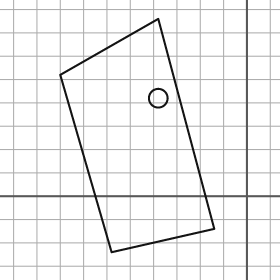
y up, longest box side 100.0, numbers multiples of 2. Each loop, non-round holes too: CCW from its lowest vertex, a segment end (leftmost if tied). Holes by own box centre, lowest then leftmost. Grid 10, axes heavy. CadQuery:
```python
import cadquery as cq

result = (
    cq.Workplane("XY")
    .moveTo(-58.0, -24.0)
    .lineTo(-14.0, -14.0)
    .lineTo(-38.0, 76.0)
    .lineTo(-80.0, 52.0)
    .close()
    .moveTo(-38.0, 42.0)
    .circle(4.0)
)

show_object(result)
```